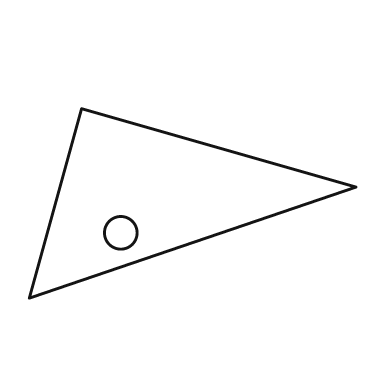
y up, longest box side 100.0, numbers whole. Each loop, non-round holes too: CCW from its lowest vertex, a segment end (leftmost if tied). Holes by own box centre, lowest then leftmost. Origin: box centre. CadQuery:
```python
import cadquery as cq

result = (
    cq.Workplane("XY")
    .moveTo(-50.0, -29.0)
    .lineTo(50.0, 5.0)
    .lineTo(-34.0, 29.0)
    .close()
    .moveTo(-22.0, -9.0)
    .circle(5.0)
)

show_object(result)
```